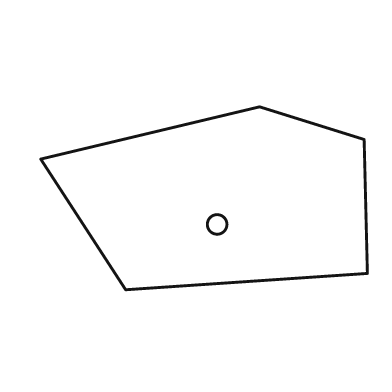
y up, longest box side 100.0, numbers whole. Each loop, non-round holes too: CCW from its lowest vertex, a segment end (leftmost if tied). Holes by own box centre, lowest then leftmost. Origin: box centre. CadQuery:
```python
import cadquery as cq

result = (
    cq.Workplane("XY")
    .moveTo(-24.0, -28.0)
    .lineTo(50.0, -23.0)
    .lineTo(49.0, 18.0)
    .lineTo(17.0, 28.0)
    .lineTo(-50.0, 12.0)
    .close()
    .moveTo(4.0, -8.0)
    .circle(3.0)
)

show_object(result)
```